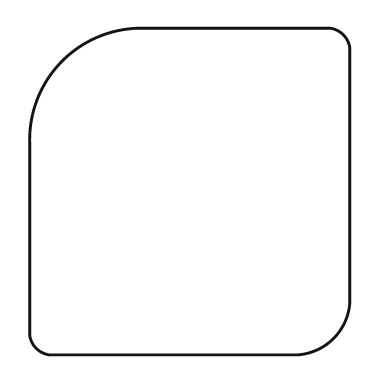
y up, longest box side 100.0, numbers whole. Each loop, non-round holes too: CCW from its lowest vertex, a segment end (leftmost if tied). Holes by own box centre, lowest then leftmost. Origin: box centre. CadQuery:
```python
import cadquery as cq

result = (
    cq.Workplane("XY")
    .moveTo(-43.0, -50.0)
    .lineTo(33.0, -50.0)
    .threePointArc((44.0, -45.0), (49.0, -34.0))
    .lineTo(49.0, 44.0)
    .threePointArc((47.0, 48.0), (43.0, 50.0))
    .lineTo(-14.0, 50.0)
    .threePointArc((-39.0, 40.0), (-49.0, 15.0))
    .lineTo(-49.0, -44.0)
    .threePointArc((-47.0, -48.0), (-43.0, -50.0))
    .close()
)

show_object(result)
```